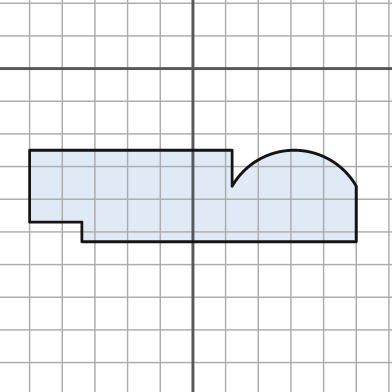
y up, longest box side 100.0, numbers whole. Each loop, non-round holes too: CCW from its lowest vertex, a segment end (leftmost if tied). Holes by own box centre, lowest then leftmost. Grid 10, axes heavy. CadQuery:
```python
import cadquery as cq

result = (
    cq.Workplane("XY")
    .moveTo(-34.0, -53.0)
    .lineTo(50.0, -53.0)
    .lineTo(50.0, -36.0)
    .threePointArc((31.0, -25.0), (12.0, -36.0))
    .lineTo(12.0, -25.0)
    .lineTo(-50.0, -25.0)
    .lineTo(-50.0, -47.0)
    .lineTo(-34.0, -47.0)
    .close()
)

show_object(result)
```